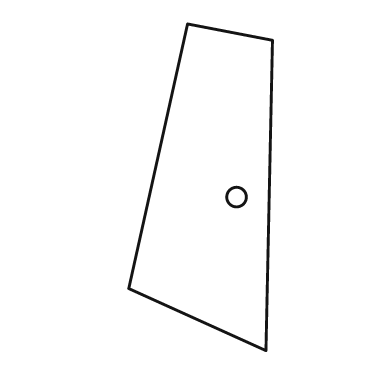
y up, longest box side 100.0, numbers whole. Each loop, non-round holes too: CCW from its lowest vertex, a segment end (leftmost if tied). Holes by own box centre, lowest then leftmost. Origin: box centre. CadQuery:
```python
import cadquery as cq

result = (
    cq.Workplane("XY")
    .moveTo(20.0, -50.0)
    .lineTo(22.0, 45.0)
    .lineTo(-4.0, 50.0)
    .lineTo(-22.0, -31.0)
    .close()
    .moveTo(11.0, -3.0)
    .circle(3.0)
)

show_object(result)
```